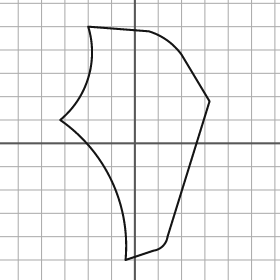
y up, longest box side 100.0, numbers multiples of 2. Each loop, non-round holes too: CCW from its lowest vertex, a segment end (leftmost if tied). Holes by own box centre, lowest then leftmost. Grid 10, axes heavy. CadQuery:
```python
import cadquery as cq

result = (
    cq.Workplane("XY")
    .moveTo(-4.0, -50.0)
    .lineTo(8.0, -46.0)
    .threePointArc((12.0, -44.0), (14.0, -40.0))
    .lineTo(32.0, 18.0)
    .lineTo(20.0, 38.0)
    .threePointArc((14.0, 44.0), (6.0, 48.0))
    .lineTo(-20.0, 50.0)
    .threePointArc((-20.0, 28.0), (-32.0, 10.0))
    .threePointArc((-10.0, -16.0), (-4.0, -50.0))
    .close()
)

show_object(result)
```